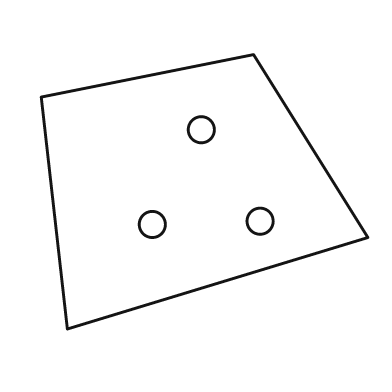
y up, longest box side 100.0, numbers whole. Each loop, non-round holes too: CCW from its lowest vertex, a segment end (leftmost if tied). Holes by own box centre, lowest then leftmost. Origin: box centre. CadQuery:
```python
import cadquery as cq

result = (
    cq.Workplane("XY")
    .moveTo(-42.0, -42.0)
    .lineTo(50.0, -14.0)
    .lineTo(15.0, 42.0)
    .lineTo(-50.0, 29.0)
    .close()
    .moveTo(-16.0, -10.0)
    .circle(4.0)
    .moveTo(17.0, -9.0)
    .circle(4.0)
    .moveTo(-1.0, 19.0)
    .circle(4.0)
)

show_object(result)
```